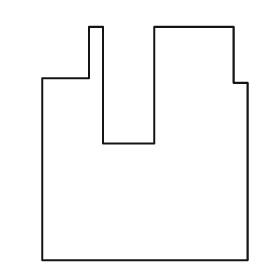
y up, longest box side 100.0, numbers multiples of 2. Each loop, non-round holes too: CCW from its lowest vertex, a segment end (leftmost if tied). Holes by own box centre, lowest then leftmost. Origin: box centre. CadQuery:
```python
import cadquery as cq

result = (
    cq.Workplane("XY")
    .moveTo(-44.0, -50.0)
    .lineTo(44.0, -50.0)
    .lineTo(44.0, 26.0)
    .lineTo(38.0, 26.0)
    .lineTo(38.0, 50.0)
    .lineTo(4.0, 50.0)
    .lineTo(4.0, 0.0)
    .lineTo(-18.0, 0.0)
    .lineTo(-18.0, 50.0)
    .lineTo(-24.0, 50.0)
    .lineTo(-24.0, 28.0)
    .lineTo(-44.0, 28.0)
    .close()
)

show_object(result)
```